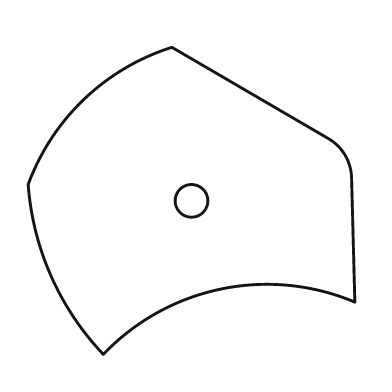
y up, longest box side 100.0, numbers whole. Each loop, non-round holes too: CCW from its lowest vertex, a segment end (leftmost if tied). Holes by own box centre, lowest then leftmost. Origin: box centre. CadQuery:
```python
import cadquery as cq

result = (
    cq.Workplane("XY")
    .moveTo(-27.0, -47.0)
    .threePointArc((9.0, -27.0), (50.0, -31.0))
    .lineTo(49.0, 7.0)
    .threePointArc((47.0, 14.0), (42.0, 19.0))
    .lineTo(-6.0, 47.0)
    .threePointArc((-33.0, 31.0), (-50.0, 5.0))
    .threePointArc((-43.0, -23.0), (-27.0, -47.0))
    .close()
    .moveTo(0.0, 0.0)
    .circle(5.0)
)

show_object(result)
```